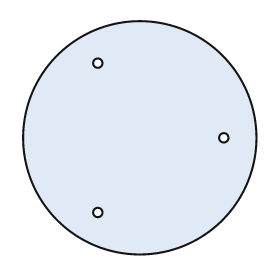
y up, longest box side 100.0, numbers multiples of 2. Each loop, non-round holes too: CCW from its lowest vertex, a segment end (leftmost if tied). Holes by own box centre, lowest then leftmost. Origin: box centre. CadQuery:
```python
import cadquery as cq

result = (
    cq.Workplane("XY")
    .moveTo(0.0, 0.0)
    .circle(50.0)
    .moveTo(-18.0, -32.0)
    .circle(2.0)
    .moveTo(36.0, 0.0)
    .circle(2.0)
    .moveTo(-18.0, 32.0)
    .circle(2.0)
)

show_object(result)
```